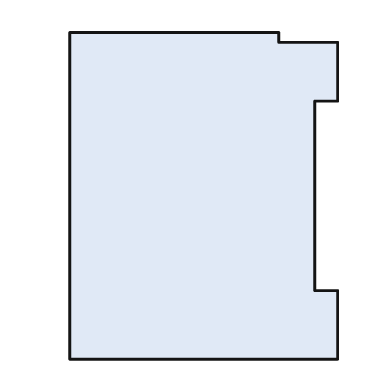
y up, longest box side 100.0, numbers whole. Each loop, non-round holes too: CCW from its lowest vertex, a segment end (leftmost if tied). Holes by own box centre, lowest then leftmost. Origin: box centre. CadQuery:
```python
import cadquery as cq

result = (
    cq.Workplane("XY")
    .moveTo(-41.0, -50.0)
    .lineTo(41.0, -50.0)
    .lineTo(41.0, -29.0)
    .lineTo(34.0, -29.0)
    .lineTo(34.0, 29.0)
    .lineTo(41.0, 29.0)
    .lineTo(41.0, 47.0)
    .lineTo(23.0, 47.0)
    .lineTo(23.0, 50.0)
    .lineTo(-41.0, 50.0)
    .close()
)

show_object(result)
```